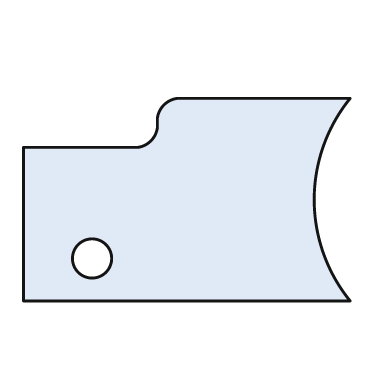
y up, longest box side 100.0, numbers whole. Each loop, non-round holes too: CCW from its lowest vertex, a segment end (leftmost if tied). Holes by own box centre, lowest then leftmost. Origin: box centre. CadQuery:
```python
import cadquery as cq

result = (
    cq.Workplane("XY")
    .moveTo(-50.0, -31.0)
    .lineTo(50.0, -31.0)
    .threePointArc((39.0, 0.0), (50.0, 31.0))
    .lineTo(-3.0, 31.0)
    .threePointArc((-7.0, 29.0), (-9.0, 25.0))
    .lineTo(-9.0, 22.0)
    .threePointArc((-11.0, 18.0), (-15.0, 16.0))
    .lineTo(-50.0, 16.0)
    .close()
    .moveTo(-29.0, -18.0)
    .circle(6.0)
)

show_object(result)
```